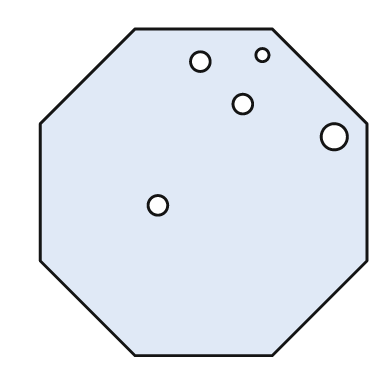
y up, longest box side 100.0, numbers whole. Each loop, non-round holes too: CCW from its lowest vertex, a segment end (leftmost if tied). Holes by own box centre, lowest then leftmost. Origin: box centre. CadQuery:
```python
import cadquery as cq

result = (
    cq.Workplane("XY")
    .moveTo(-21.0, -50.0)
    .lineTo(21.0, -50.0)
    .lineTo(50.0, -21.0)
    .lineTo(50.0, 21.0)
    .lineTo(21.0, 50.0)
    .lineTo(-21.0, 50.0)
    .lineTo(-50.0, 21.0)
    .lineTo(-50.0, -21.0)
    .close()
    .moveTo(-14.0, -4.0)
    .circle(3.0)
    .moveTo(40.0, 17.0)
    .circle(4.0)
    .moveTo(12.0, 27.0)
    .circle(3.0)
    .moveTo(-1.0, 40.0)
    .circle(3.0)
    .moveTo(18.0, 42.0)
    .circle(2.0)
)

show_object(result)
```